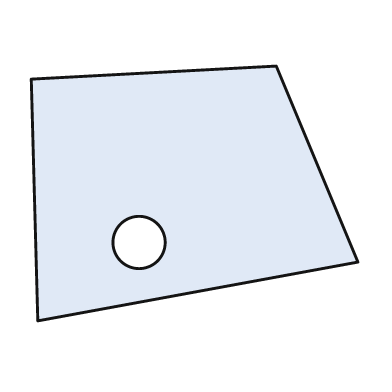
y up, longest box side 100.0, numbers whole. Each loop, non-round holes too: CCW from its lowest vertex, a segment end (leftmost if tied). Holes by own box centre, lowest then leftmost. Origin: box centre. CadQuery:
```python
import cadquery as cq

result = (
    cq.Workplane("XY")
    .moveTo(-48.0, -39.0)
    .lineTo(50.0, -21.0)
    .lineTo(25.0, 39.0)
    .lineTo(-50.0, 35.0)
    .close()
    .moveTo(-17.0, -15.0)
    .circle(8.0)
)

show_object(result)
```